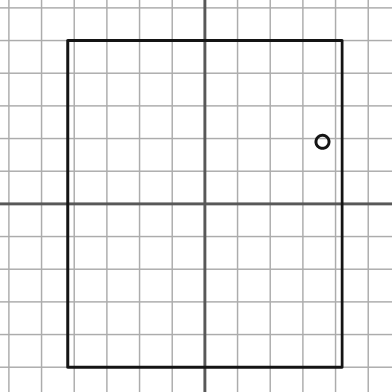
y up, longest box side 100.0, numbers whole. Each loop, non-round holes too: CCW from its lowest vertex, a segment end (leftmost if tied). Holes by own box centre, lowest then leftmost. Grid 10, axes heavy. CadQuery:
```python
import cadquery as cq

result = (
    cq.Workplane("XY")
    .moveTo(-42.0, -50.0)
    .lineTo(42.0, -50.0)
    .lineTo(42.0, 50.0)
    .lineTo(-42.0, 50.0)
    .close()
    .moveTo(36.0, 19.0)
    .circle(2.0)
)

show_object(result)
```